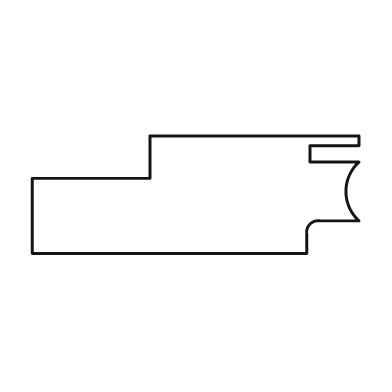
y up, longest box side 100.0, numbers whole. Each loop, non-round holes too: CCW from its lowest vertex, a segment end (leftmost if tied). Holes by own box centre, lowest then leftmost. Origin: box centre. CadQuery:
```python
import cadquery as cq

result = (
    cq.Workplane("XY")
    .moveTo(-50.0, -18.0)
    .lineTo(34.0, -18.0)
    .lineTo(34.0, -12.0)
    .threePointArc((35.0, -9.0), (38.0, -8.0))
    .lineTo(50.0, -8.0)
    .threePointArc((46.0, 1.0), (50.0, 10.0))
    .lineTo(35.0, 10.0)
    .lineTo(35.0, 15.0)
    .lineTo(50.0, 15.0)
    .lineTo(50.0, 18.0)
    .lineTo(-14.0, 18.0)
    .lineTo(-14.0, 5.0)
    .lineTo(-50.0, 5.0)
    .close()
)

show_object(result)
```